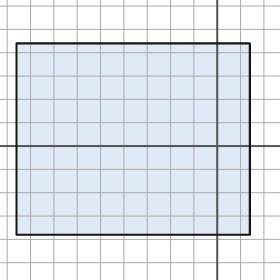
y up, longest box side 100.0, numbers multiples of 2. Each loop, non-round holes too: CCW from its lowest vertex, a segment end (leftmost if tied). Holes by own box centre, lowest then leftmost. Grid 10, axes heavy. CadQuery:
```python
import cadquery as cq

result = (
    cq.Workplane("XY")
    .moveTo(-86.0, -38.0)
    .lineTo(14.0, -38.0)
    .lineTo(14.0, 44.0)
    .lineTo(-86.0, 44.0)
    .close()
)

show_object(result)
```